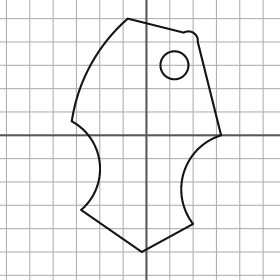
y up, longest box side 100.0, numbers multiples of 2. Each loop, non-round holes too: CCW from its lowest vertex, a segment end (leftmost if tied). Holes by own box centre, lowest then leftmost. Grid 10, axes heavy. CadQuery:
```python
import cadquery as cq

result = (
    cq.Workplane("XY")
    .moveTo(-2.0, -50.0)
    .lineTo(20.0, -38.0)
    .threePointArc((16.0, -16.0), (32.0, 0.0))
    .lineTo(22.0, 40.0)
    .threePointArc((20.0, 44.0), (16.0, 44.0))
    .lineTo(-8.0, 50.0)
    .threePointArc((-24.0, 30.0), (-32.0, 6.0))
    .threePointArc((-20.0, -12.0), (-28.0, -32.0))
    .close()
    .moveTo(12.0, 30.0)
    .circle(6.0)
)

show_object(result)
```